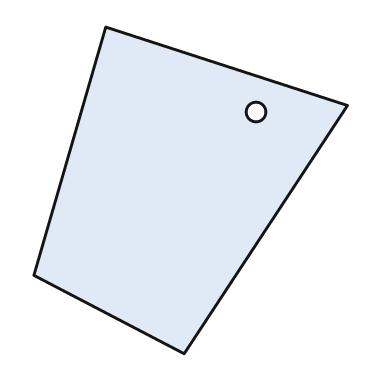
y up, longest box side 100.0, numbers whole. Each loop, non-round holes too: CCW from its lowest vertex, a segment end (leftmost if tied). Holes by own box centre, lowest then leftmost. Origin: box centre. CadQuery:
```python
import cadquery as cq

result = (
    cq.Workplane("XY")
    .moveTo(-2.0, -50.0)
    .lineTo(48.0, 26.0)
    .lineTo(-26.0, 50.0)
    .lineTo(-48.0, -26.0)
    .close()
    .moveTo(20.0, 24.0)
    .circle(3.0)
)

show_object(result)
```